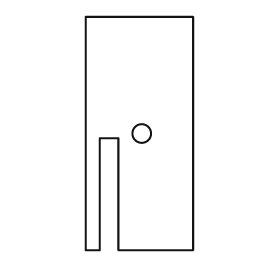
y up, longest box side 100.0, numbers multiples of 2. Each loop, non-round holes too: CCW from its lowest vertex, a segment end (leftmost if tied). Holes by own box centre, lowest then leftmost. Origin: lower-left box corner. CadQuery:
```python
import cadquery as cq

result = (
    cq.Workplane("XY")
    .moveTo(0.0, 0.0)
    .lineTo(6.0, 0.0)
    .lineTo(6.0, 48.0)
    .lineTo(14.0, 48.0)
    .lineTo(14.0, 0.0)
    .lineTo(46.0, 0.0)
    .lineTo(46.0, 100.0)
    .lineTo(0.0, 100.0)
    .close()
    .moveTo(24.0, 50.0)
    .circle(4.0)
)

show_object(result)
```